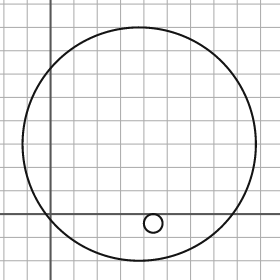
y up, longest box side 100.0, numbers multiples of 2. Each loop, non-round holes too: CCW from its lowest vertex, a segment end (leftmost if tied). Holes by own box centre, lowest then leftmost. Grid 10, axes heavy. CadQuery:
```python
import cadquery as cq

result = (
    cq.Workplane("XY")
    .moveTo(38.0, 30.0)
    .circle(50.0)
    .moveTo(44.0, -4.0)
    .circle(4.0)
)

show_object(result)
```